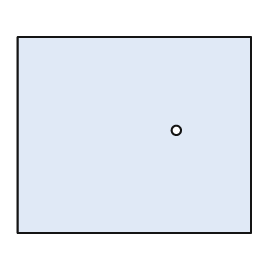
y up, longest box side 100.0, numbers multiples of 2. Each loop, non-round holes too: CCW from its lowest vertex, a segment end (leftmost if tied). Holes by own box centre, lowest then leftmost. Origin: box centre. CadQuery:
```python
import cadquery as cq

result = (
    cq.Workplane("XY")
    .moveTo(-50.0, -42.0)
    .lineTo(50.0, -42.0)
    .lineTo(50.0, 42.0)
    .lineTo(-50.0, 42.0)
    .close()
    .moveTo(18.0, 2.0)
    .circle(2.0)
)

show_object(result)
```